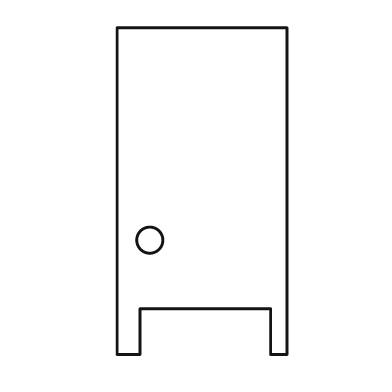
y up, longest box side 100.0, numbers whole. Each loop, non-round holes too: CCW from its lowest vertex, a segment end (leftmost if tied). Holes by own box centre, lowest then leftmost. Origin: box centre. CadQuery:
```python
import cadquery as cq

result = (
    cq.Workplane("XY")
    .moveTo(-26.0, -50.0)
    .lineTo(-19.0, -50.0)
    .lineTo(-19.0, -36.0)
    .lineTo(21.0, -36.0)
    .lineTo(21.0, -50.0)
    .lineTo(26.0, -50.0)
    .lineTo(26.0, 50.0)
    .lineTo(-26.0, 50.0)
    .close()
    .moveTo(-16.0, -15.0)
    .circle(4.0)
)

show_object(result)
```